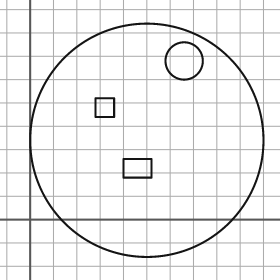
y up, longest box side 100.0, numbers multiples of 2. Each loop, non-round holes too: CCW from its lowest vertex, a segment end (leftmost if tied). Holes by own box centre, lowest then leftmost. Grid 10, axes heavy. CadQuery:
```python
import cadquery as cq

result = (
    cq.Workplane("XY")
    .moveTo(50.0, 34.0)
    .circle(50.0)
    .moveTo(40.0, 18.0)
    .lineTo(52.0, 18.0)
    .lineTo(52.0, 26.0)
    .lineTo(40.0, 26.0)
    .close()
    .moveTo(28.0, 44.0)
    .lineTo(36.0, 44.0)
    .lineTo(36.0, 52.0)
    .lineTo(28.0, 52.0)
    .close()
    .moveTo(66.0, 68.0)
    .circle(8.0)
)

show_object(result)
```